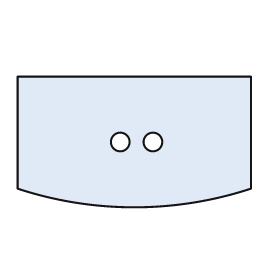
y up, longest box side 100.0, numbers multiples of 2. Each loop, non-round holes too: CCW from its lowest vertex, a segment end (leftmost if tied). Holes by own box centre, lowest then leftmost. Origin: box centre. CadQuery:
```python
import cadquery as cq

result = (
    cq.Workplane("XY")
    .moveTo(-50.0, -20.0)
    .threePointArc((0.0, -28.0), (50.0, -20.0))
    .lineTo(50.0, 28.0)
    .lineTo(-50.0, 28.0)
    .close()
    .moveTo(-6.0, 0.0)
    .circle(4.0)
    .moveTo(8.0, 0.0)
    .circle(4.0)
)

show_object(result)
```